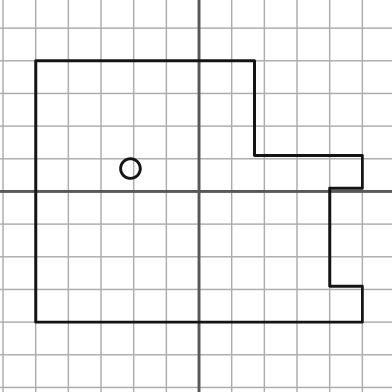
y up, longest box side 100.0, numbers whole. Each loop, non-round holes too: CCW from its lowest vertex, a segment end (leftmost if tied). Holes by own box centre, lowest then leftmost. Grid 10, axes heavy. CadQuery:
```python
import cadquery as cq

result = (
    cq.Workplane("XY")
    .moveTo(-50.0, -40.0)
    .lineTo(50.0, -40.0)
    .lineTo(50.0, -29.0)
    .lineTo(40.0, -29.0)
    .lineTo(40.0, 1.0)
    .lineTo(50.0, 1.0)
    .lineTo(50.0, 11.0)
    .lineTo(17.0, 11.0)
    .lineTo(17.0, 40.0)
    .lineTo(-50.0, 40.0)
    .close()
    .moveTo(-21.0, 7.0)
    .circle(3.0)
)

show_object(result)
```